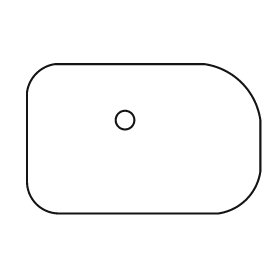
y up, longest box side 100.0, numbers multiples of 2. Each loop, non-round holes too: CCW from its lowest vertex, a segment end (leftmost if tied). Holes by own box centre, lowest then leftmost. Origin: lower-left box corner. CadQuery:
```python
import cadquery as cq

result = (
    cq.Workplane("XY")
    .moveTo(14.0, 0.0)
    .lineTo(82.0, 0.0)
    .threePointArc((94.0, 6.0), (100.0, 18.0))
    .lineTo(100.0, 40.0)
    .threePointArc((92.0, 56.0), (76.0, 64.0))
    .lineTo(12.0, 64.0)
    .threePointArc((4.0, 60.0), (0.0, 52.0))
    .lineTo(0.0, 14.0)
    .threePointArc((4.0, 4.0), (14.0, 0.0))
    .close()
    .moveTo(42.0, 40.0)
    .circle(4.0)
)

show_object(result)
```